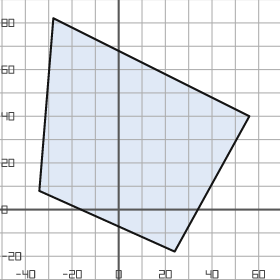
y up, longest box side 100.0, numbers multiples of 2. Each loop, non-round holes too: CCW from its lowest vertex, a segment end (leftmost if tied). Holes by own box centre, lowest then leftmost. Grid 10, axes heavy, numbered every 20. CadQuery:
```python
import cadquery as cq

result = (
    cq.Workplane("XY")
    .moveTo(24.0, -18.0)
    .lineTo(56.0, 40.0)
    .lineTo(-28.0, 82.0)
    .lineTo(-34.0, 8.0)
    .close()
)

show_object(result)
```